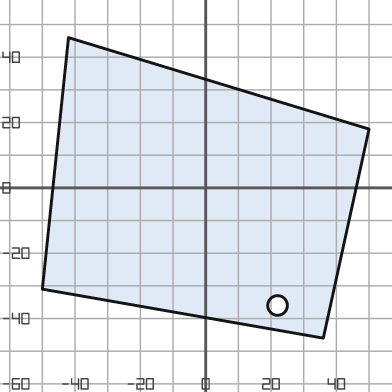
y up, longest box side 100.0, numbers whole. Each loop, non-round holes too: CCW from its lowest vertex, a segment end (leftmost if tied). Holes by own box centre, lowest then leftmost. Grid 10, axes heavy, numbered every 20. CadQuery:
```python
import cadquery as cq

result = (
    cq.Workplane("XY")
    .moveTo(36.0, -46.0)
    .lineTo(50.0, 18.0)
    .lineTo(-42.0, 46.0)
    .lineTo(-50.0, -31.0)
    .close()
    .moveTo(22.0, -36.0)
    .circle(3.0)
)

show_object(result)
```